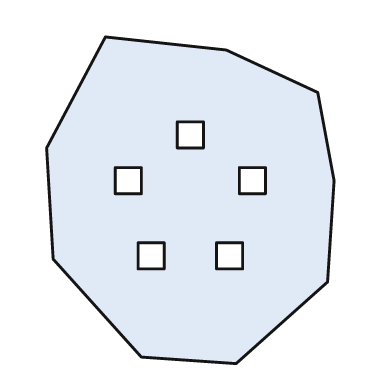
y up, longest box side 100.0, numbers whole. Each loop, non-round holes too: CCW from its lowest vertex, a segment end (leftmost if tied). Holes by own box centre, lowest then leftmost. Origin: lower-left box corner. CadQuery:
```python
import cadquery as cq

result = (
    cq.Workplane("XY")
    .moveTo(58.0, 0.0)
    .lineTo(86.0, 25.0)
    .lineTo(88.0, 56.0)
    .lineTo(83.0, 83.0)
    .lineTo(55.0, 96.0)
    .lineTo(18.0, 100.0)
    .lineTo(0.0, 66.0)
    .lineTo(2.0, 32.0)
    .lineTo(29.0, 2.0)
    .close()
    .moveTo(28.0, 29.0)
    .lineTo(36.0, 29.0)
    .lineTo(36.0, 37.0)
    .lineTo(28.0, 37.0)
    .close()
    .moveTo(52.0, 29.0)
    .lineTo(60.0, 29.0)
    .lineTo(60.0, 37.0)
    .lineTo(52.0, 37.0)
    .close()
    .moveTo(21.0, 52.0)
    .lineTo(29.0, 52.0)
    .lineTo(29.0, 60.0)
    .lineTo(21.0, 60.0)
    .close()
    .moveTo(59.0, 52.0)
    .lineTo(67.0, 52.0)
    .lineTo(67.0, 60.0)
    .lineTo(59.0, 60.0)
    .close()
    .moveTo(40.0, 66.0)
    .lineTo(48.0, 66.0)
    .lineTo(48.0, 74.0)
    .lineTo(40.0, 74.0)
    .close()
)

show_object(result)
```